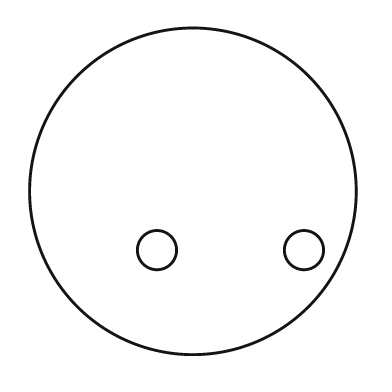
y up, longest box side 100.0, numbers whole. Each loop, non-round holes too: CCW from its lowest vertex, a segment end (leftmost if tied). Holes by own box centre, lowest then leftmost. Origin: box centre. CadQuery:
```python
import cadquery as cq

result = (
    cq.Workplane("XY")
    .moveTo(0.0, 0.0)
    .circle(50.0)
    .moveTo(-11.0, -18.0)
    .circle(6.0)
    .moveTo(34.0, -18.0)
    .circle(6.0)
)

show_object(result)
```